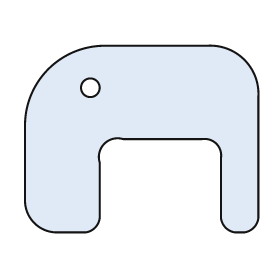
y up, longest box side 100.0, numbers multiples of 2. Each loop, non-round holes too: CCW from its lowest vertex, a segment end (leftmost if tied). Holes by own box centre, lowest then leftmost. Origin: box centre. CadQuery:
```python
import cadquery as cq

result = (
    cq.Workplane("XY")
    .moveTo(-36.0, -40.0)
    .lineTo(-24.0, -40.0)
    .threePointArc((-20.0, -38.0), (-18.0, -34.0))
    .lineTo(-18.0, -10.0)
    .threePointArc((-16.0, -2.0), (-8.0, 0.0))
    .lineTo(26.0, 0.0)
    .threePointArc((32.0, -2.0), (34.0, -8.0))
    .lineTo(34.0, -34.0)
    .threePointArc((36.0, -38.0), (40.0, -40.0))
    .lineTo(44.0, -40.0)
    .threePointArc((48.0, -38.0), (50.0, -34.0))
    .lineTo(50.0, 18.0)
    .threePointArc((44.0, 34.0), (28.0, 40.0))
    .lineTo(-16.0, 40.0)
    .threePointArc((-40.0, 30.0), (-50.0, 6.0))
    .lineTo(-50.0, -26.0)
    .threePointArc((-46.0, -36.0), (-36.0, -40.0))
    .close()
    .moveTo(-22.0, 22.0)
    .circle(4.0)
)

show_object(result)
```